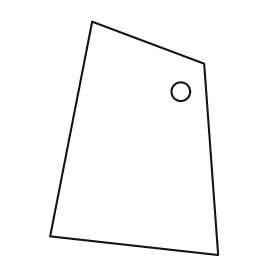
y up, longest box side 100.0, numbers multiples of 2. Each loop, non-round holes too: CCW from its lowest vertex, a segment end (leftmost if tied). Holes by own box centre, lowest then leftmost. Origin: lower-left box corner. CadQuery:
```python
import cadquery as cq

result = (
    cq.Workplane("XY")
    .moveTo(72.0, 0.0)
    .lineTo(66.0, 82.0)
    .lineTo(18.0, 100.0)
    .lineTo(0.0, 8.0)
    .close()
    .moveTo(56.0, 70.0)
    .circle(4.0)
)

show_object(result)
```